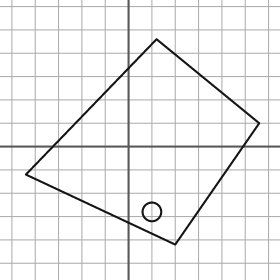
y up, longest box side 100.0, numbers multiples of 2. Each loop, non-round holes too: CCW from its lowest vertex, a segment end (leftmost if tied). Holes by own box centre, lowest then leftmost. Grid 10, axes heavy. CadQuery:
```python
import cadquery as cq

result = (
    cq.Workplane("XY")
    .moveTo(20.0, -42.0)
    .lineTo(56.0, 10.0)
    .lineTo(12.0, 46.0)
    .lineTo(-44.0, -12.0)
    .close()
    .moveTo(10.0, -28.0)
    .circle(4.0)
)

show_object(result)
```